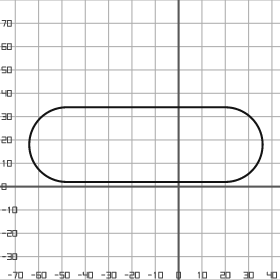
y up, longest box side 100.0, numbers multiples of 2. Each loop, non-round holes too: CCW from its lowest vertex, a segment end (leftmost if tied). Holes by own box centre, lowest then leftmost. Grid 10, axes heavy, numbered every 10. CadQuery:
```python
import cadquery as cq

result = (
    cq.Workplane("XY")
    .moveTo(-48.0, 2.0)
    .lineTo(20.0, 2.0)
    .threePointArc((36.0, 18.0), (20.0, 34.0))
    .lineTo(-48.0, 34.0)
    .threePointArc((-64.0, 18.0), (-48.0, 2.0))
    .close()
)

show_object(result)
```